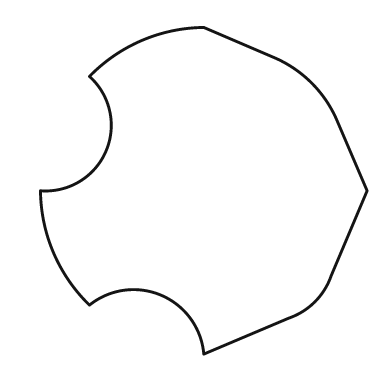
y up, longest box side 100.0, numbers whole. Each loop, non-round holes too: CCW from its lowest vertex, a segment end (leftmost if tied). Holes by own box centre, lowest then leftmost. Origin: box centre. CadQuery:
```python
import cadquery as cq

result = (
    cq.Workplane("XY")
    .moveTo(0.0, -50.0)
    .lineTo(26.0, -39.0)
    .threePointArc((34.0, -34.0), (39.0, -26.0))
    .lineTo(50.0, 0.0)
    .lineTo(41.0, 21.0)
    .threePointArc((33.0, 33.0), (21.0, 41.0))
    .lineTo(0.0, 50.0)
    .threePointArc((-19.0, 46.0), (-35.0, 35.0))
    .threePointArc((-30.0, 12.0), (-50.0, 0.0))
    .threePointArc((-46.0, -19.0), (-35.0, -35.0))
    .threePointArc((-13.0, -32.0), (0.0, -50.0))
    .close()
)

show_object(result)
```